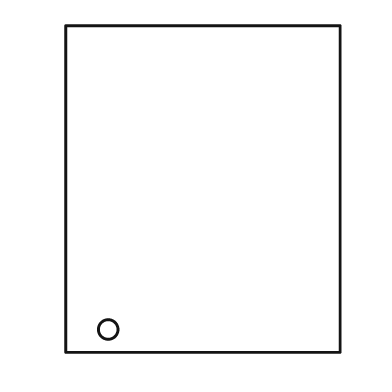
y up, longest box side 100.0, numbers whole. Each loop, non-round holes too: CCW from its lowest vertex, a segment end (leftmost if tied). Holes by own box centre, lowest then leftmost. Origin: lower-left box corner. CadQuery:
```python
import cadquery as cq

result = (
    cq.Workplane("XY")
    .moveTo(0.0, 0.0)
    .lineTo(84.0, 0.0)
    .lineTo(84.0, 100.0)
    .lineTo(0.0, 100.0)
    .close()
    .moveTo(13.0, 7.0)
    .circle(3.0)
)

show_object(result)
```